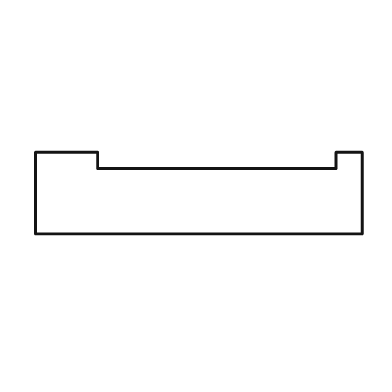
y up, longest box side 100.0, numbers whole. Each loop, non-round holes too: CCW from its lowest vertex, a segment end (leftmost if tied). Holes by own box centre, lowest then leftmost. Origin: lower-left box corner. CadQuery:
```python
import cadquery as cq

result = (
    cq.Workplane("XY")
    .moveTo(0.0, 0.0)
    .lineTo(100.0, 0.0)
    .lineTo(100.0, 25.0)
    .lineTo(92.0, 25.0)
    .lineTo(92.0, 20.0)
    .lineTo(19.0, 20.0)
    .lineTo(19.0, 25.0)
    .lineTo(0.0, 25.0)
    .close()
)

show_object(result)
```